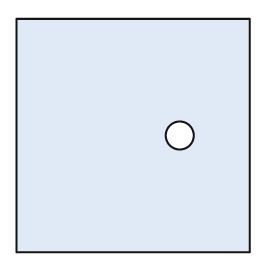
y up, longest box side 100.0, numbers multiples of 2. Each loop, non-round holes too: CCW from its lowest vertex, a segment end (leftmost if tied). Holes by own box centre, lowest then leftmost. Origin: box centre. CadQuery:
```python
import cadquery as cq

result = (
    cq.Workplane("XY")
    .moveTo(-50.0, -50.0)
    .lineTo(50.0, -50.0)
    .lineTo(50.0, 50.0)
    .lineTo(-50.0, 50.0)
    .close()
    .moveTo(20.0, 0.0)
    .circle(6.0)
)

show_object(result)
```